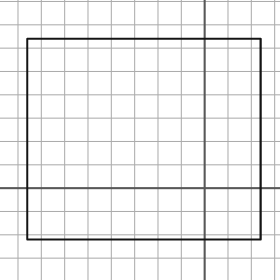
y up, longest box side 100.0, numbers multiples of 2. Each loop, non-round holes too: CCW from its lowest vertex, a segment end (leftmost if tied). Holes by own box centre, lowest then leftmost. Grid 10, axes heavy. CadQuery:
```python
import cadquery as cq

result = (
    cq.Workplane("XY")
    .moveTo(-76.0, -22.0)
    .lineTo(24.0, -22.0)
    .lineTo(24.0, 64.0)
    .lineTo(-76.0, 64.0)
    .close()
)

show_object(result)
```